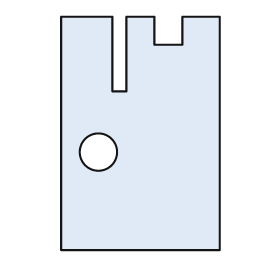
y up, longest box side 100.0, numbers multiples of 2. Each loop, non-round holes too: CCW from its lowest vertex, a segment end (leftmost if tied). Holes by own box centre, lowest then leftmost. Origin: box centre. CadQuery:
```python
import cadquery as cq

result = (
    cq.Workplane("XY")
    .moveTo(-34.0, -50.0)
    .lineTo(34.0, -50.0)
    .lineTo(34.0, 50.0)
    .lineTo(18.0, 50.0)
    .lineTo(18.0, 38.0)
    .lineTo(6.0, 38.0)
    .lineTo(6.0, 50.0)
    .lineTo(-6.0, 50.0)
    .lineTo(-6.0, 18.0)
    .lineTo(-12.0, 18.0)
    .lineTo(-12.0, 50.0)
    .lineTo(-34.0, 50.0)
    .close()
    .moveTo(-18.0, -8.0)
    .circle(8.0)
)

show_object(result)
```